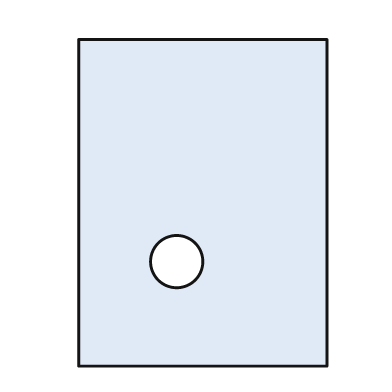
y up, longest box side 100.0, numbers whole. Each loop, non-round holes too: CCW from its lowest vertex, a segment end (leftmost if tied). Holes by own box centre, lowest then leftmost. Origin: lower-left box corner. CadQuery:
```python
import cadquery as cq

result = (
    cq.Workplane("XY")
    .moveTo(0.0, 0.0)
    .lineTo(76.0, 0.0)
    .lineTo(76.0, 100.0)
    .lineTo(0.0, 100.0)
    .close()
    .moveTo(30.0, 32.0)
    .circle(8.0)
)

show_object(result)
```